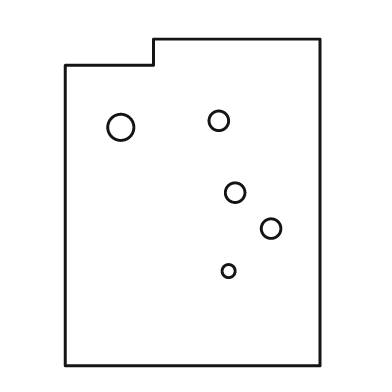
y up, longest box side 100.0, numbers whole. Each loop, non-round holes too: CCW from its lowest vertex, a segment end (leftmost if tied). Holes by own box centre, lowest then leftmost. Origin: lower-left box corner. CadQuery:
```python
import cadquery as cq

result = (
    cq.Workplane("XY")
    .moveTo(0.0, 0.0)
    .lineTo(78.0, 0.0)
    .lineTo(78.0, 100.0)
    .lineTo(27.0, 100.0)
    .lineTo(27.0, 92.0)
    .lineTo(0.0, 92.0)
    .close()
    .moveTo(50.0, 29.0)
    .circle(2.0)
    .moveTo(63.0, 42.0)
    .circle(3.0)
    .moveTo(52.0, 53.0)
    .circle(3.0)
    .moveTo(17.0, 73.0)
    .circle(4.0)
    .moveTo(47.0, 75.0)
    .circle(3.0)
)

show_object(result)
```